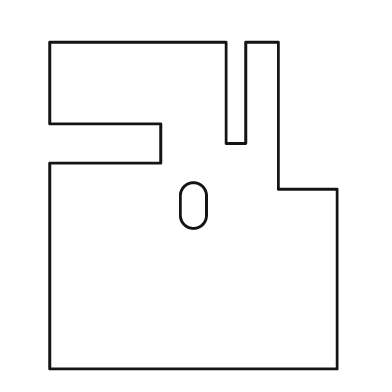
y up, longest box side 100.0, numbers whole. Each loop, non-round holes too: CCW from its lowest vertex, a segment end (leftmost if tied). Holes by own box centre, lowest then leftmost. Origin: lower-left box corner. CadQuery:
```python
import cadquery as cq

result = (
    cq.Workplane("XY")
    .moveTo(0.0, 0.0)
    .lineTo(88.0, 0.0)
    .lineTo(88.0, 55.0)
    .lineTo(70.0, 55.0)
    .lineTo(70.0, 100.0)
    .lineTo(60.0, 100.0)
    .lineTo(60.0, 69.0)
    .lineTo(54.0, 69.0)
    .lineTo(54.0, 100.0)
    .lineTo(0.0, 100.0)
    .lineTo(0.0, 75.0)
    .lineTo(34.0, 75.0)
    .lineTo(34.0, 63.0)
    .lineTo(0.0, 63.0)
    .close()
    .moveTo(40.0, 47.0)
    .threePointArc((44.0, 43.0), (48.0, 47.0))
    .lineTo(48.0, 53.0)
    .threePointArc((44.0, 57.0), (40.0, 53.0))
    .close()
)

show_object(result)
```